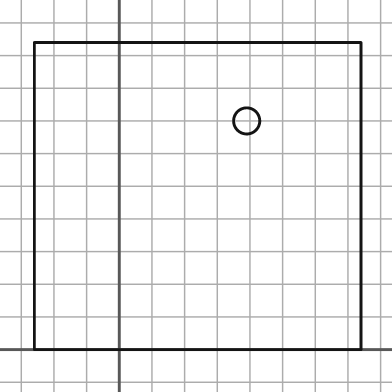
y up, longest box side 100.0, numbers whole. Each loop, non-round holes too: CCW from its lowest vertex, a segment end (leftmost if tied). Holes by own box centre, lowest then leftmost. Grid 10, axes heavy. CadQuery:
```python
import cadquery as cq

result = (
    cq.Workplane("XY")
    .moveTo(-26.0, 0.0)
    .lineTo(74.0, 0.0)
    .lineTo(74.0, 94.0)
    .lineTo(-26.0, 94.0)
    .close()
    .moveTo(39.0, 70.0)
    .circle(4.0)
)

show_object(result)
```